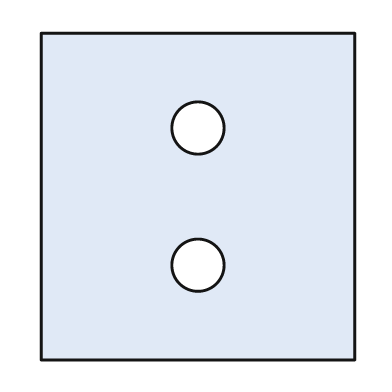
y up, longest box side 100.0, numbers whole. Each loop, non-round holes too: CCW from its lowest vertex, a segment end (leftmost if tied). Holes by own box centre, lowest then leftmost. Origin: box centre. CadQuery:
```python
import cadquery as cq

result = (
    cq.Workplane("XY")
    .moveTo(-48.0, -50.0)
    .lineTo(48.0, -50.0)
    .lineTo(48.0, 50.0)
    .lineTo(-48.0, 50.0)
    .close()
    .moveTo(0.0, -21.0)
    .circle(8.0)
    .moveTo(0.0, 21.0)
    .circle(8.0)
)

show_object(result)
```